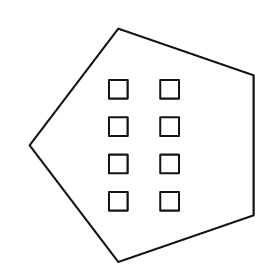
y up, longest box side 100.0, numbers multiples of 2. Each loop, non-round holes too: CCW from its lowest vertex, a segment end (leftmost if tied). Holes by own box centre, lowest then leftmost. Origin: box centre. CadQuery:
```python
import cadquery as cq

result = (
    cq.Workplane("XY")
    .moveTo(-10.0, -50.0)
    .lineTo(48.0, -30.0)
    .lineTo(48.0, 30.0)
    .lineTo(-10.0, 50.0)
    .lineTo(-48.0, 0.0)
    .close()
    .moveTo(-14.0, -28.0)
    .lineTo(-6.0, -28.0)
    .lineTo(-6.0, -20.0)
    .lineTo(-14.0, -20.0)
    .close()
    .moveTo(8.0, -28.0)
    .lineTo(16.0, -28.0)
    .lineTo(16.0, -20.0)
    .lineTo(8.0, -20.0)
    .close()
    .moveTo(-14.0, -12.0)
    .lineTo(-6.0, -12.0)
    .lineTo(-6.0, -4.0)
    .lineTo(-14.0, -4.0)
    .close()
    .moveTo(8.0, -12.0)
    .lineTo(16.0, -12.0)
    .lineTo(16.0, -4.0)
    .lineTo(8.0, -4.0)
    .close()
    .moveTo(-14.0, 4.0)
    .lineTo(-6.0, 4.0)
    .lineTo(-6.0, 12.0)
    .lineTo(-14.0, 12.0)
    .close()
    .moveTo(8.0, 4.0)
    .lineTo(16.0, 4.0)
    .lineTo(16.0, 12.0)
    .lineTo(8.0, 12.0)
    .close()
    .moveTo(-14.0, 20.0)
    .lineTo(-6.0, 20.0)
    .lineTo(-6.0, 28.0)
    .lineTo(-14.0, 28.0)
    .close()
    .moveTo(8.0, 20.0)
    .lineTo(16.0, 20.0)
    .lineTo(16.0, 28.0)
    .lineTo(8.0, 28.0)
    .close()
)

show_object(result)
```